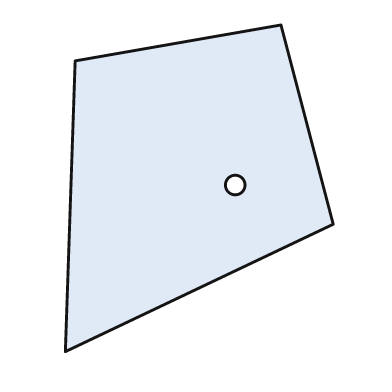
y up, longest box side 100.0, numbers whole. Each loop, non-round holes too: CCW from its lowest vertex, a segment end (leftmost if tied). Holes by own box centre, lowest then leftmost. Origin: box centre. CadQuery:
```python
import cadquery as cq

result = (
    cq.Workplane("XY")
    .moveTo(-41.0, -50.0)
    .lineTo(41.0, -11.0)
    .lineTo(25.0, 50.0)
    .lineTo(-38.0, 39.0)
    .close()
    .moveTo(11.0, 1.0)
    .circle(3.0)
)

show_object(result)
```